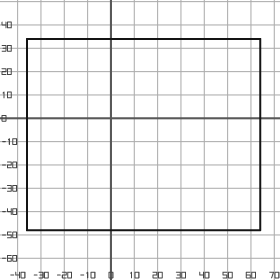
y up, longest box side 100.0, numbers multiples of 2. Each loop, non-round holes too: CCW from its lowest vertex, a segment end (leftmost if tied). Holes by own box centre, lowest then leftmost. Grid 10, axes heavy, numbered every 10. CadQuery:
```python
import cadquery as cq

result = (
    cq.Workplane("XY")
    .moveTo(-36.0, -48.0)
    .lineTo(64.0, -48.0)
    .lineTo(64.0, 34.0)
    .lineTo(-36.0, 34.0)
    .close()
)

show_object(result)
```